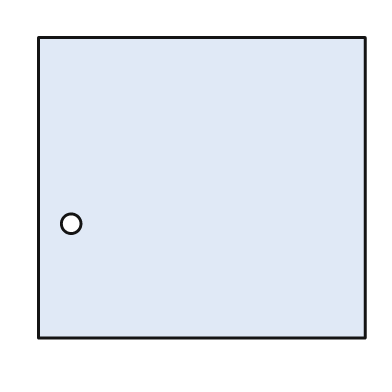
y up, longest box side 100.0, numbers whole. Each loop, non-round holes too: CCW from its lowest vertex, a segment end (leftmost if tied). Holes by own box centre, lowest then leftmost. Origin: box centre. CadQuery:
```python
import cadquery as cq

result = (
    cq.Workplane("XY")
    .moveTo(-50.0, -46.0)
    .lineTo(50.0, -46.0)
    .lineTo(50.0, 46.0)
    .lineTo(-50.0, 46.0)
    .close()
    .moveTo(-40.0, -11.0)
    .circle(3.0)
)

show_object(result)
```